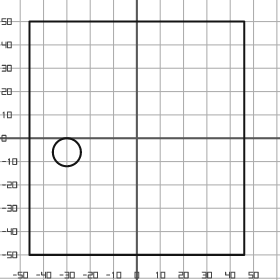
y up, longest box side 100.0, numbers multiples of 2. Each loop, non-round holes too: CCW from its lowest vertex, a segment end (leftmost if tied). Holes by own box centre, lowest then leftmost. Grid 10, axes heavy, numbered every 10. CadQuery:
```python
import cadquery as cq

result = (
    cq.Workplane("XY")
    .moveTo(-46.0, -50.0)
    .lineTo(46.0, -50.0)
    .lineTo(46.0, 50.0)
    .lineTo(-46.0, 50.0)
    .close()
    .moveTo(-30.0, -6.0)
    .circle(6.0)
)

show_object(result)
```